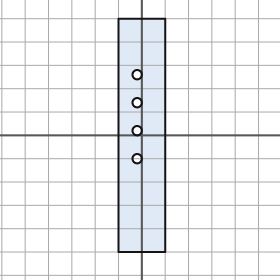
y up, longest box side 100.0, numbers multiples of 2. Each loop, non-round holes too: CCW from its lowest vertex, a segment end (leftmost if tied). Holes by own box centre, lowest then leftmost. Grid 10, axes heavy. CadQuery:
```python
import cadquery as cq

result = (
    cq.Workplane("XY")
    .moveTo(-10.0, -50.0)
    .lineTo(10.0, -50.0)
    .lineTo(10.0, 50.0)
    .lineTo(-10.0, 50.0)
    .close()
    .moveTo(-2.0, -10.0)
    .circle(2.0)
    .moveTo(-2.0, 2.0)
    .circle(2.0)
    .moveTo(-2.0, 14.0)
    .circle(2.0)
    .moveTo(-2.0, 26.0)
    .circle(2.0)
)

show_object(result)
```